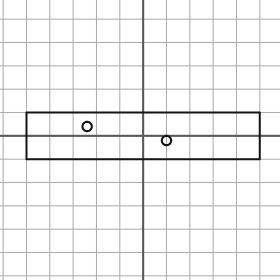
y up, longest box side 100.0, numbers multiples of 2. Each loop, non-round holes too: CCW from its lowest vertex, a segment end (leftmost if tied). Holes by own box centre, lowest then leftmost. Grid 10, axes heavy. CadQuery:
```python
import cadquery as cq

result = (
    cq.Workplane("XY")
    .moveTo(-50.0, -10.0)
    .lineTo(50.0, -10.0)
    .lineTo(50.0, 10.0)
    .lineTo(-50.0, 10.0)
    .close()
    .moveTo(10.0, -2.0)
    .circle(2.0)
    .moveTo(-24.0, 4.0)
    .circle(2.0)
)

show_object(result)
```